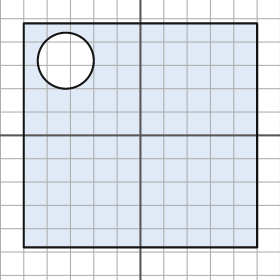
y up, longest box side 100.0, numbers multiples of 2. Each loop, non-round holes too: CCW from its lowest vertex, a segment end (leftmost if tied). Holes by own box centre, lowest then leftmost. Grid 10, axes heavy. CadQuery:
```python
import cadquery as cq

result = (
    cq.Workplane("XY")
    .moveTo(-50.0, -48.0)
    .lineTo(50.0, -48.0)
    .lineTo(50.0, 48.0)
    .lineTo(-50.0, 48.0)
    .close()
    .moveTo(-32.0, 32.0)
    .circle(12.0)
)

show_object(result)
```